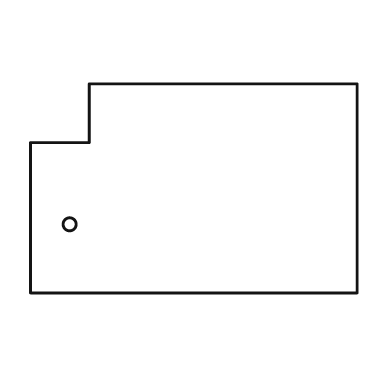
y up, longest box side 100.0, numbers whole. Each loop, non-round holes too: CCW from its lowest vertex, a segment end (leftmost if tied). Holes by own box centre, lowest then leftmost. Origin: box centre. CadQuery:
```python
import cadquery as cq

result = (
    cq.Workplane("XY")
    .moveTo(-50.0, -32.0)
    .lineTo(50.0, -32.0)
    .lineTo(50.0, 32.0)
    .lineTo(-32.0, 32.0)
    .lineTo(-32.0, 14.0)
    .lineTo(-50.0, 14.0)
    .close()
    .moveTo(-38.0, -11.0)
    .circle(2.0)
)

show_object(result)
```